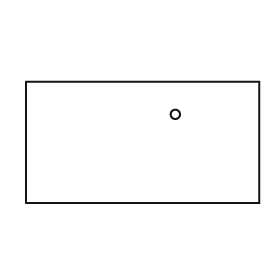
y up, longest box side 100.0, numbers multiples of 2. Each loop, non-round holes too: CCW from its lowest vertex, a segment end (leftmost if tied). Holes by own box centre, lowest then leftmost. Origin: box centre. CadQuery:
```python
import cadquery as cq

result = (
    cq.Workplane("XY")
    .moveTo(-50.0, -26.0)
    .lineTo(50.0, -26.0)
    .lineTo(50.0, 26.0)
    .lineTo(-50.0, 26.0)
    .close()
    .moveTo(14.0, 12.0)
    .circle(2.0)
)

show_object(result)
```